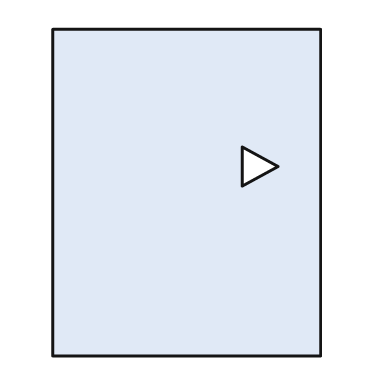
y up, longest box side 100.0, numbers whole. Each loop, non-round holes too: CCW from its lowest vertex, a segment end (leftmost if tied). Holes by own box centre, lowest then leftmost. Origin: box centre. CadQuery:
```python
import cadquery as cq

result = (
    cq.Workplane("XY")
    .moveTo(-41.0, -50.0)
    .lineTo(41.0, -50.0)
    .lineTo(41.0, 50.0)
    .lineTo(-41.0, 50.0)
    .close()
    .moveTo(17.0, 2.0)
    .lineTo(28.0, 8.0)
    .lineTo(17.0, 14.0)
    .close()
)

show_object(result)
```